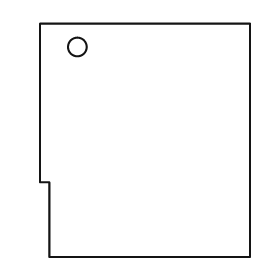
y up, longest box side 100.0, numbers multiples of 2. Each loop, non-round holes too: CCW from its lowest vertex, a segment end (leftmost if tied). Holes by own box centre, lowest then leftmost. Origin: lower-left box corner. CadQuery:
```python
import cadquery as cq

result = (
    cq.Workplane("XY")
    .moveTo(4.0, 0.0)
    .lineTo(90.0, 0.0)
    .lineTo(90.0, 100.0)
    .lineTo(0.0, 100.0)
    .lineTo(0.0, 32.0)
    .lineTo(4.0, 32.0)
    .close()
    .moveTo(16.0, 90.0)
    .circle(4.0)
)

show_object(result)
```